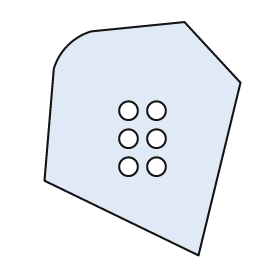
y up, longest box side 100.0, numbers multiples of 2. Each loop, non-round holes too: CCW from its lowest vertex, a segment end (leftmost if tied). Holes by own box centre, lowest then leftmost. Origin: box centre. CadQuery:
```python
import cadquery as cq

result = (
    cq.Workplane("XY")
    .moveTo(24.0, -50.0)
    .lineTo(42.0, 24.0)
    .lineTo(18.0, 50.0)
    .lineTo(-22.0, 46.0)
    .threePointArc((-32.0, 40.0), (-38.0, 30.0))
    .lineTo(-42.0, -18.0)
    .close()
    .moveTo(-6.0, -12.0)
    .circle(4.0)
    .moveTo(6.0, -12.0)
    .circle(4.0)
    .moveTo(-6.0, 0.0)
    .circle(4.0)
    .moveTo(6.0, 0.0)
    .circle(4.0)
    .moveTo(-6.0, 12.0)
    .circle(4.0)
    .moveTo(6.0, 12.0)
    .circle(4.0)
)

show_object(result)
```